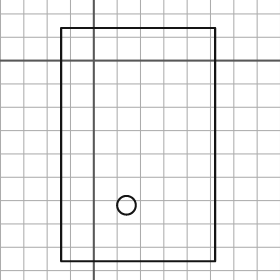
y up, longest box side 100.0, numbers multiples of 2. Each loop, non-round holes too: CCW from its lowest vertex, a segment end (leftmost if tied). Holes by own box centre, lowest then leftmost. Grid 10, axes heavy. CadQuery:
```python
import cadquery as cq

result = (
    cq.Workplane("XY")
    .moveTo(-14.0, -86.0)
    .lineTo(52.0, -86.0)
    .lineTo(52.0, 14.0)
    .lineTo(-14.0, 14.0)
    .close()
    .moveTo(14.0, -62.0)
    .circle(4.0)
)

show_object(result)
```